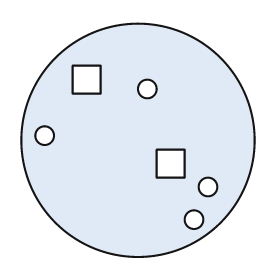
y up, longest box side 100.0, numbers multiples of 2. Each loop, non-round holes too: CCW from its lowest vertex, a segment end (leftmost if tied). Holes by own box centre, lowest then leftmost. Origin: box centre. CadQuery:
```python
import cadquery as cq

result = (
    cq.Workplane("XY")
    .moveTo(0.0, 0.0)
    .circle(50.0)
    .moveTo(24.0, -34.0)
    .circle(4.0)
    .moveTo(30.0, -20.0)
    .circle(4.0)
    .moveTo(8.0, -16.0)
    .lineTo(20.0, -16.0)
    .lineTo(20.0, -4.0)
    .lineTo(8.0, -4.0)
    .close()
    .moveTo(-40.0, 2.0)
    .circle(4.0)
    .moveTo(4.0, 22.0)
    .circle(4.0)
    .moveTo(-28.0, 20.0)
    .lineTo(-16.0, 20.0)
    .lineTo(-16.0, 32.0)
    .lineTo(-28.0, 32.0)
    .close()
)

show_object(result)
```